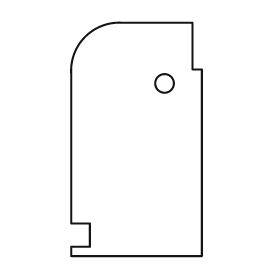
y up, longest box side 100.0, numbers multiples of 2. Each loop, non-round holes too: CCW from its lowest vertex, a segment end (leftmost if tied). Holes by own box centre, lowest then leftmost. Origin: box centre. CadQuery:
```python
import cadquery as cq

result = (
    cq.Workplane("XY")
    .moveTo(-28.0, -50.0)
    .lineTo(28.0, -50.0)
    .lineTo(28.0, 30.0)
    .lineTo(24.0, 30.0)
    .lineTo(24.0, 50.0)
    .lineTo(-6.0, 50.0)
    .threePointArc((-22.0, 44.0), (-28.0, 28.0))
    .lineTo(-28.0, -36.0)
    .lineTo(-20.0, -36.0)
    .lineTo(-20.0, -46.0)
    .lineTo(-28.0, -46.0)
    .close()
    .moveTo(12.0, 24.0)
    .circle(4.0)
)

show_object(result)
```